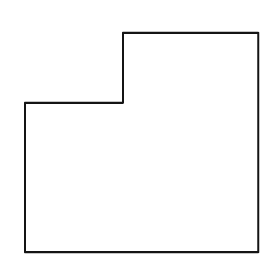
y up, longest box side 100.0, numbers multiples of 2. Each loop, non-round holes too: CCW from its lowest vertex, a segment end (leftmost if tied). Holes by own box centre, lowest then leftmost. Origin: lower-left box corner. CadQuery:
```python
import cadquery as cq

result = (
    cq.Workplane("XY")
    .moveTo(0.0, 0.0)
    .lineTo(100.0, 0.0)
    .lineTo(100.0, 94.0)
    .lineTo(42.0, 94.0)
    .lineTo(42.0, 64.0)
    .lineTo(0.0, 64.0)
    .close()
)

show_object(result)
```